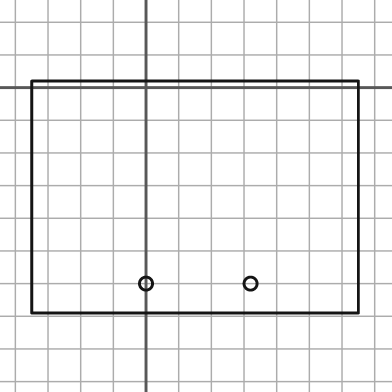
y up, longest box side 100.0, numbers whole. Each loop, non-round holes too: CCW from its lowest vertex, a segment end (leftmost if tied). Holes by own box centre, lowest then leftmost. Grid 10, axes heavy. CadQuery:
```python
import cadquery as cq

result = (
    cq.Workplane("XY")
    .moveTo(-35.0, -69.0)
    .lineTo(65.0, -69.0)
    .lineTo(65.0, 2.0)
    .lineTo(-35.0, 2.0)
    .close()
    .moveTo(0.0, -60.0)
    .circle(2.0)
    .moveTo(32.0, -60.0)
    .circle(2.0)
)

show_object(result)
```